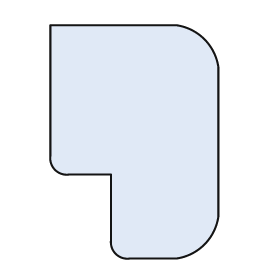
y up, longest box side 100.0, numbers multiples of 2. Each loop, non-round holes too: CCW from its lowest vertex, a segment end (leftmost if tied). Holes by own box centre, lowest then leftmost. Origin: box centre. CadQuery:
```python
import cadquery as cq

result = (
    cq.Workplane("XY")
    .moveTo(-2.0, -50.0)
    .lineTo(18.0, -50.0)
    .threePointArc((30.0, -44.0), (36.0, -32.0))
    .lineTo(36.0, 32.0)
    .threePointArc((30.0, 44.0), (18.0, 50.0))
    .lineTo(-36.0, 50.0)
    .lineTo(-36.0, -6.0)
    .threePointArc((-34.0, -12.0), (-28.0, -14.0))
    .lineTo(-10.0, -14.0)
    .lineTo(-10.0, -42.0)
    .threePointArc((-8.0, -48.0), (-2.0, -50.0))
    .close()
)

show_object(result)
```